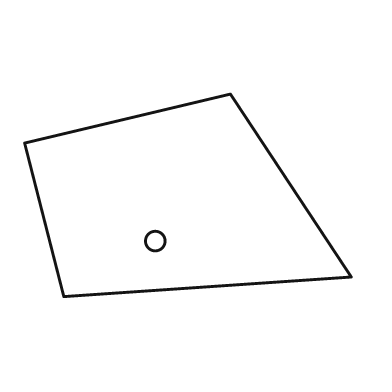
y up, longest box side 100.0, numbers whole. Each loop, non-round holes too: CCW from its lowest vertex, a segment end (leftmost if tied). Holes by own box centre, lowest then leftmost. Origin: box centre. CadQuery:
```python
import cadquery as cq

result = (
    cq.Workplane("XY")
    .moveTo(-38.0, -31.0)
    .lineTo(50.0, -25.0)
    .lineTo(13.0, 31.0)
    .lineTo(-50.0, 16.0)
    .close()
    .moveTo(-10.0, -14.0)
    .circle(3.0)
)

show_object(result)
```